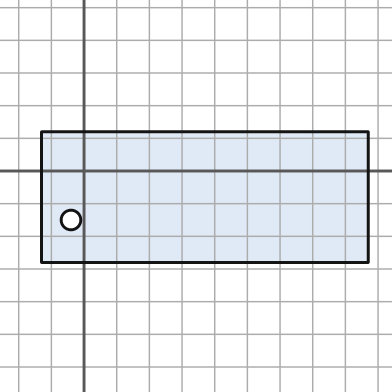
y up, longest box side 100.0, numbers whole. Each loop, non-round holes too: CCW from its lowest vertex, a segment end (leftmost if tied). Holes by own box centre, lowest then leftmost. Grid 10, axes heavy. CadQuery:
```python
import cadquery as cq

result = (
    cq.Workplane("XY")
    .moveTo(-13.0, -28.0)
    .lineTo(87.0, -28.0)
    .lineTo(87.0, 12.0)
    .lineTo(-13.0, 12.0)
    .close()
    .moveTo(-4.0, -15.0)
    .circle(3.0)
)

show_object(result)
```